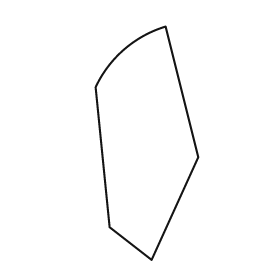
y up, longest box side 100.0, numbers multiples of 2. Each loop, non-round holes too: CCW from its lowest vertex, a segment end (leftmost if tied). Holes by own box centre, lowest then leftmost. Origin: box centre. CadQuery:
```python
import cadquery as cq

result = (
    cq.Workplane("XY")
    .moveTo(2.0, -50.0)
    .lineTo(22.0, -6.0)
    .lineTo(8.0, 50.0)
    .threePointArc((-10.0, 40.0), (-22.0, 24.0))
    .lineTo(-16.0, -36.0)
    .close()
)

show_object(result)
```